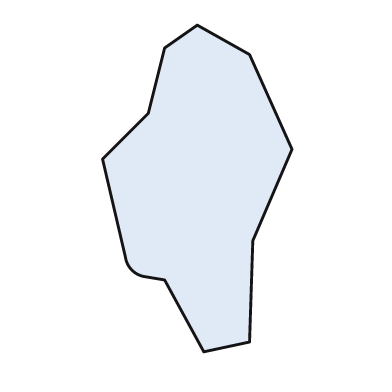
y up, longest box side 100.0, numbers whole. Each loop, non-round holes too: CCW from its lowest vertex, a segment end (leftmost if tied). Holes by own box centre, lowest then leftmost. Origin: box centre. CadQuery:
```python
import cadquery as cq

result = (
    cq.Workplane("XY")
    .moveTo(2.0, -50.0)
    .lineTo(16.0, -47.0)
    .lineTo(17.0, -16.0)
    .lineTo(29.0, 12.0)
    .lineTo(16.0, 41.0)
    .lineTo(0.0, 50.0)
    .lineTo(-10.0, 43.0)
    .lineTo(-15.0, 23.0)
    .lineTo(-29.0, 9.0)
    .lineTo(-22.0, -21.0)
    .threePointArc((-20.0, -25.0), (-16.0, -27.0))
    .lineTo(-10.0, -28.0)
    .close()
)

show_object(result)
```